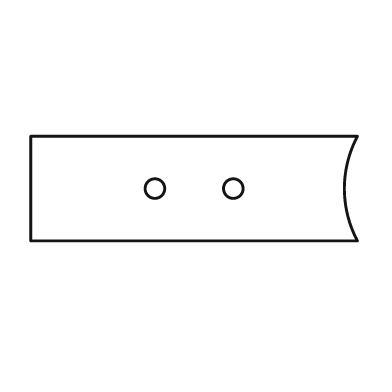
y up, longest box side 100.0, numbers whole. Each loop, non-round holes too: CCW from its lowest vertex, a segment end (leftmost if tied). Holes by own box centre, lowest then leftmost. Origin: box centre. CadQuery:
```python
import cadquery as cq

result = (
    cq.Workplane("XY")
    .moveTo(-50.0, -16.0)
    .lineTo(50.0, -16.0)
    .threePointArc((46.0, 0.0), (50.0, 16.0))
    .lineTo(-50.0, 16.0)
    .close()
    .moveTo(-12.0, 0.0)
    .circle(3.0)
    .moveTo(12.0, 0.0)
    .circle(3.0)
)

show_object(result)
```